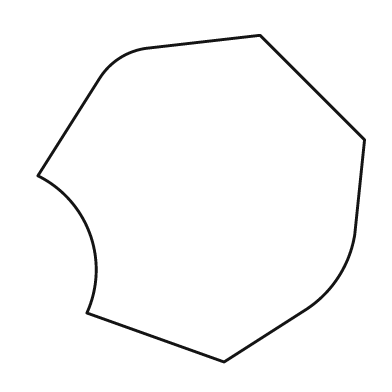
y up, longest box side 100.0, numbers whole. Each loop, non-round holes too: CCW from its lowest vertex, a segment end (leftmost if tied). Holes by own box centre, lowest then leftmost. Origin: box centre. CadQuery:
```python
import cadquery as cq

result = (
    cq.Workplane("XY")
    .moveTo(7.0, -50.0)
    .lineTo(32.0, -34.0)
    .threePointArc((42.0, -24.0), (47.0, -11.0))
    .lineTo(50.0, 18.0)
    .lineTo(18.0, 50.0)
    .lineTo(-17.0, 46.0)
    .threePointArc((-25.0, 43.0), (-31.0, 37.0))
    .lineTo(-50.0, 7.0)
    .threePointArc((-34.0, -11.0), (-35.0, -35.0))
    .close()
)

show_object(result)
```